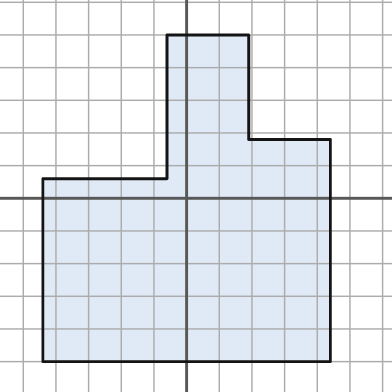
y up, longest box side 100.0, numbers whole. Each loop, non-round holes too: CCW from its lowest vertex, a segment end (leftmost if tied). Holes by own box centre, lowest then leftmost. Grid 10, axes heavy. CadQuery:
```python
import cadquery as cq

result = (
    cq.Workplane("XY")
    .moveTo(-44.0, -50.0)
    .lineTo(44.0, -50.0)
    .lineTo(44.0, 18.0)
    .lineTo(19.0, 18.0)
    .lineTo(19.0, 50.0)
    .lineTo(-6.0, 50.0)
    .lineTo(-6.0, 6.0)
    .lineTo(-44.0, 6.0)
    .close()
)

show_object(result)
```